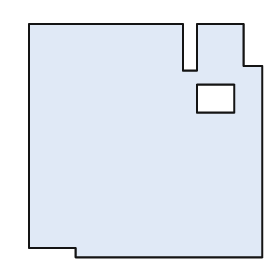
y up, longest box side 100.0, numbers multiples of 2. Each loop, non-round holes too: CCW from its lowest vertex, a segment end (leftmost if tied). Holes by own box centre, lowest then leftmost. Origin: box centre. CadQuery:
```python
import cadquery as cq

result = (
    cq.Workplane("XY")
    .moveTo(-30.0, -50.0)
    .lineTo(50.0, -50.0)
    .lineTo(50.0, 32.0)
    .lineTo(42.0, 32.0)
    .lineTo(42.0, 50.0)
    .lineTo(22.0, 50.0)
    .lineTo(22.0, 30.0)
    .lineTo(16.0, 30.0)
    .lineTo(16.0, 50.0)
    .lineTo(-50.0, 50.0)
    .lineTo(-50.0, -46.0)
    .lineTo(-30.0, -46.0)
    .close()
    .moveTo(22.0, 12.0)
    .lineTo(38.0, 12.0)
    .lineTo(38.0, 24.0)
    .lineTo(22.0, 24.0)
    .close()
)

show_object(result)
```